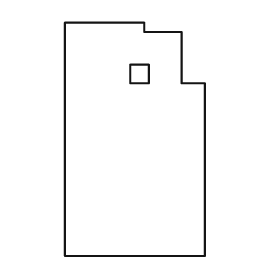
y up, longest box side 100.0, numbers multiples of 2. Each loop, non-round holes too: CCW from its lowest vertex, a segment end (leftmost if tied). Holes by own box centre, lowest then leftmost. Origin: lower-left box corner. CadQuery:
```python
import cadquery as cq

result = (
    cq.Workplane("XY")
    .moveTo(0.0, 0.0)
    .lineTo(60.0, 0.0)
    .lineTo(60.0, 74.0)
    .lineTo(50.0, 74.0)
    .lineTo(50.0, 96.0)
    .lineTo(34.0, 96.0)
    .lineTo(34.0, 100.0)
    .lineTo(0.0, 100.0)
    .close()
    .moveTo(28.0, 74.0)
    .lineTo(36.0, 74.0)
    .lineTo(36.0, 82.0)
    .lineTo(28.0, 82.0)
    .close()
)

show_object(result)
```